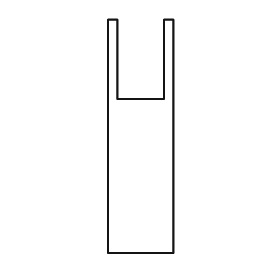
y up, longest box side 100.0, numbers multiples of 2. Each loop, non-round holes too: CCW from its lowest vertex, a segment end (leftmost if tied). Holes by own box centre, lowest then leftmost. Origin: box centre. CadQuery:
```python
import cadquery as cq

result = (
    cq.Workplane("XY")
    .moveTo(-14.0, -50.0)
    .lineTo(14.0, -50.0)
    .lineTo(14.0, 50.0)
    .lineTo(10.0, 50.0)
    .lineTo(10.0, 16.0)
    .lineTo(-10.0, 16.0)
    .lineTo(-10.0, 50.0)
    .lineTo(-14.0, 50.0)
    .close()
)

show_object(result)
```